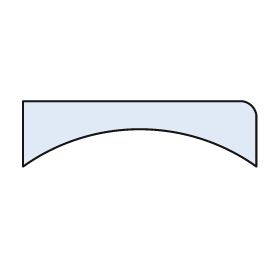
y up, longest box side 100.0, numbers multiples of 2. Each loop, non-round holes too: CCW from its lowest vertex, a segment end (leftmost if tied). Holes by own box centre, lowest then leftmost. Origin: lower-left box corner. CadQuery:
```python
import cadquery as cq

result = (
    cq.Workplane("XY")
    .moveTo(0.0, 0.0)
    .threePointArc((50.0, 16.0), (100.0, 0.0))
    .lineTo(100.0, 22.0)
    .threePointArc((98.0, 26.0), (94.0, 28.0))
    .lineTo(0.0, 28.0)
    .close()
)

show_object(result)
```